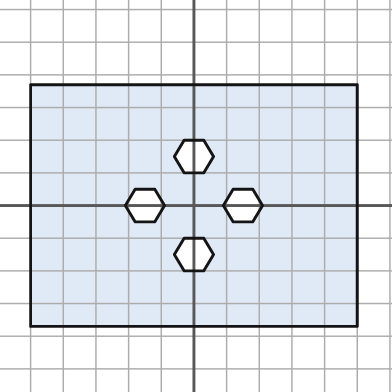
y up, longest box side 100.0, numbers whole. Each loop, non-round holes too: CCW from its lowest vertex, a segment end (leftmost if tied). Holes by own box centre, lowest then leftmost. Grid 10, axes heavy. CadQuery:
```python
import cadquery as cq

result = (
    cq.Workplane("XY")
    .moveTo(-50.0, -37.0)
    .lineTo(50.0, -37.0)
    .lineTo(50.0, 37.0)
    .lineTo(-50.0, 37.0)
    .close()
    .moveTo(-3.0, -20.0)
    .lineTo(3.0, -20.0)
    .lineTo(6.0, -15.0)
    .lineTo(3.0, -10.0)
    .lineTo(-3.0, -10.0)
    .lineTo(-6.0, -15.0)
    .close()
    .moveTo(-18.0, -5.0)
    .lineTo(-12.0, -5.0)
    .lineTo(-9.0, 0.0)
    .lineTo(-12.0, 5.0)
    .lineTo(-18.0, 5.0)
    .lineTo(-21.0, 0.0)
    .close()
    .moveTo(12.0, -5.0)
    .lineTo(18.0, -5.0)
    .lineTo(21.0, 0.0)
    .lineTo(18.0, 5.0)
    .lineTo(12.0, 5.0)
    .lineTo(9.0, 0.0)
    .close()
    .moveTo(-3.0, 10.0)
    .lineTo(3.0, 10.0)
    .lineTo(6.0, 15.0)
    .lineTo(3.0, 20.0)
    .lineTo(-3.0, 20.0)
    .lineTo(-6.0, 15.0)
    .close()
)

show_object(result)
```